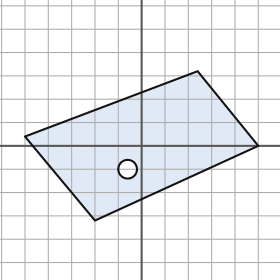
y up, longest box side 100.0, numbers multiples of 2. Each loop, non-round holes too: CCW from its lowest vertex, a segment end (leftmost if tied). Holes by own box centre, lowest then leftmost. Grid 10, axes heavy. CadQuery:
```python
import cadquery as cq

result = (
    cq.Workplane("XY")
    .moveTo(-20.0, -32.0)
    .lineTo(50.0, 0.0)
    .lineTo(24.0, 32.0)
    .lineTo(-50.0, 4.0)
    .close()
    .moveTo(-6.0, -10.0)
    .circle(4.0)
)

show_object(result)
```